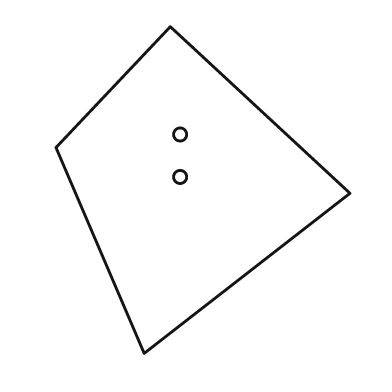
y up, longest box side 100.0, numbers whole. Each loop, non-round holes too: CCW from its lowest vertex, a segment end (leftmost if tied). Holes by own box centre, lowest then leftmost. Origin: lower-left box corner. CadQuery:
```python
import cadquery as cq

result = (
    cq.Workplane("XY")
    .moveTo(27.0, 0.0)
    .lineTo(90.0, 49.0)
    .lineTo(35.0, 100.0)
    .lineTo(0.0, 63.0)
    .close()
    .moveTo(38.0, 54.0)
    .circle(2.0)
    .moveTo(38.0, 67.0)
    .circle(2.0)
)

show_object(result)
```